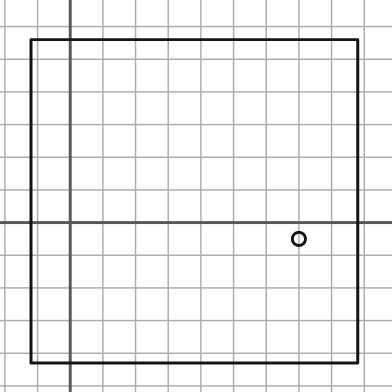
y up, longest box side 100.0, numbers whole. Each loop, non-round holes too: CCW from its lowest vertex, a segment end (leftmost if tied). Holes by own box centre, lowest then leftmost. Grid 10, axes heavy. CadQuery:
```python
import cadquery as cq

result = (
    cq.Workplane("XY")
    .moveTo(-12.0, -43.0)
    .lineTo(88.0, -43.0)
    .lineTo(88.0, 56.0)
    .lineTo(-12.0, 56.0)
    .close()
    .moveTo(70.0, -5.0)
    .circle(2.0)
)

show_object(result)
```